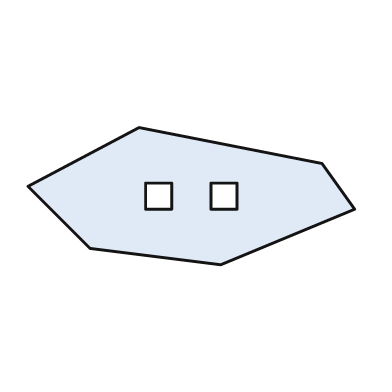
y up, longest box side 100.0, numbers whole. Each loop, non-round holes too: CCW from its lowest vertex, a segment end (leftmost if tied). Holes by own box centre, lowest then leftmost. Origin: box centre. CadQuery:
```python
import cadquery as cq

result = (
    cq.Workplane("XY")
    .moveTo(9.0, -21.0)
    .lineTo(50.0, -4.0)
    .lineTo(40.0, 10.0)
    .lineTo(-16.0, 21.0)
    .lineTo(-50.0, 3.0)
    .lineTo(-31.0, -16.0)
    .close()
    .moveTo(-14.0, -4.0)
    .lineTo(-6.0, -4.0)
    .lineTo(-6.0, 4.0)
    .lineTo(-14.0, 4.0)
    .close()
    .moveTo(6.0, -4.0)
    .lineTo(14.0, -4.0)
    .lineTo(14.0, 4.0)
    .lineTo(6.0, 4.0)
    .close()
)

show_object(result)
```